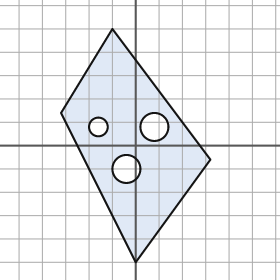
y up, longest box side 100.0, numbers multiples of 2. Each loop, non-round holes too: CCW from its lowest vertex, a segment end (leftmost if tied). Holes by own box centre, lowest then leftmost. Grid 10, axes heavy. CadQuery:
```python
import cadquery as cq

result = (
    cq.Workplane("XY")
    .moveTo(0.0, -50.0)
    .lineTo(32.0, -6.0)
    .lineTo(-10.0, 50.0)
    .lineTo(-32.0, 14.0)
    .close()
    .moveTo(-4.0, -10.0)
    .circle(6.0)
    .moveTo(-16.0, 8.0)
    .circle(4.0)
    .moveTo(8.0, 8.0)
    .circle(6.0)
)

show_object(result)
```